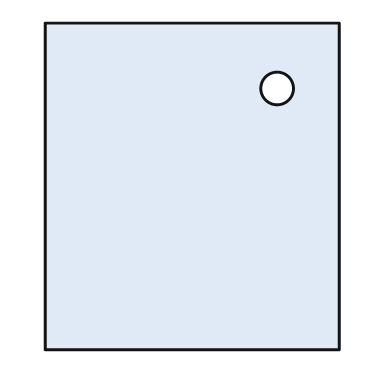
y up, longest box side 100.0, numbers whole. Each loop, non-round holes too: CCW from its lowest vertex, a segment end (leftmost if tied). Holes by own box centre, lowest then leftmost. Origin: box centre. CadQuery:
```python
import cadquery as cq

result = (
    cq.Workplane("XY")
    .moveTo(-45.0, -50.0)
    .lineTo(45.0, -50.0)
    .lineTo(45.0, 50.0)
    .lineTo(-45.0, 50.0)
    .close()
    .moveTo(26.0, 30.0)
    .circle(5.0)
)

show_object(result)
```